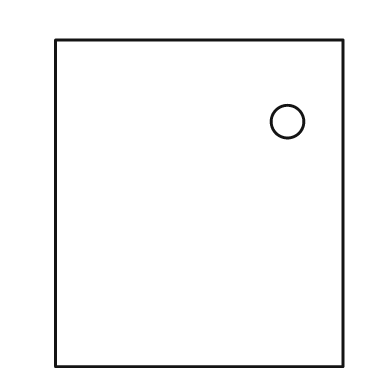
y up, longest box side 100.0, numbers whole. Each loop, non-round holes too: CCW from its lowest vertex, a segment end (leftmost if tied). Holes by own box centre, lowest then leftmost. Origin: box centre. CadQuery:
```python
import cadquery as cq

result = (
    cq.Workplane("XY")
    .moveTo(-44.0, -50.0)
    .lineTo(44.0, -50.0)
    .lineTo(44.0, 50.0)
    .lineTo(-44.0, 50.0)
    .close()
    .moveTo(27.0, 25.0)
    .circle(5.0)
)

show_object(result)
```